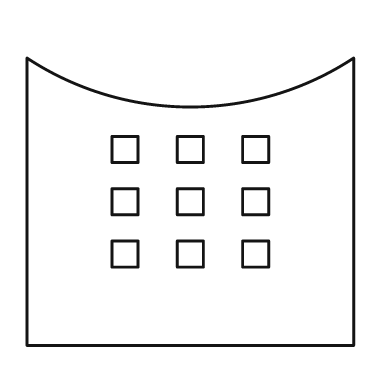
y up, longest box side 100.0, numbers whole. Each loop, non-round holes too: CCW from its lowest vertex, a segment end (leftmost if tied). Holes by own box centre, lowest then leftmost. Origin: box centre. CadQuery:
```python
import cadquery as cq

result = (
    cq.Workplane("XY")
    .moveTo(-50.0, -44.0)
    .lineTo(50.0, -44.0)
    .lineTo(50.0, 44.0)
    .threePointArc((0.0, 29.0), (-50.0, 44.0))
    .close()
    .moveTo(-24.0, -20.0)
    .lineTo(-16.0, -20.0)
    .lineTo(-16.0, -12.0)
    .lineTo(-24.0, -12.0)
    .close()
    .moveTo(-4.0, -20.0)
    .lineTo(4.0, -20.0)
    .lineTo(4.0, -12.0)
    .lineTo(-4.0, -12.0)
    .close()
    .moveTo(16.0, -20.0)
    .lineTo(24.0, -20.0)
    .lineTo(24.0, -12.0)
    .lineTo(16.0, -12.0)
    .close()
    .moveTo(-24.0, -4.0)
    .lineTo(-16.0, -4.0)
    .lineTo(-16.0, 4.0)
    .lineTo(-24.0, 4.0)
    .close()
    .moveTo(-4.0, -4.0)
    .lineTo(4.0, -4.0)
    .lineTo(4.0, 4.0)
    .lineTo(-4.0, 4.0)
    .close()
    .moveTo(16.0, -4.0)
    .lineTo(24.0, -4.0)
    .lineTo(24.0, 4.0)
    .lineTo(16.0, 4.0)
    .close()
    .moveTo(-24.0, 12.0)
    .lineTo(-16.0, 12.0)
    .lineTo(-16.0, 20.0)
    .lineTo(-24.0, 20.0)
    .close()
    .moveTo(-4.0, 12.0)
    .lineTo(4.0, 12.0)
    .lineTo(4.0, 20.0)
    .lineTo(-4.0, 20.0)
    .close()
    .moveTo(16.0, 12.0)
    .lineTo(24.0, 12.0)
    .lineTo(24.0, 20.0)
    .lineTo(16.0, 20.0)
    .close()
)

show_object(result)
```